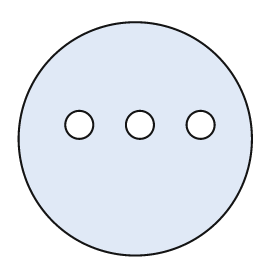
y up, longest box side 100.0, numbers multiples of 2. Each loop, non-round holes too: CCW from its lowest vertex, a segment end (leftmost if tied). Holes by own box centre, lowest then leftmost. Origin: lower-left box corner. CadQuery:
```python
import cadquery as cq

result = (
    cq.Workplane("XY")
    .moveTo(50.0, 50.0)
    .circle(50.0)
    .moveTo(26.0, 56.0)
    .circle(6.0)
    .moveTo(52.0, 56.0)
    .circle(6.0)
    .moveTo(78.0, 56.0)
    .circle(6.0)
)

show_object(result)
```